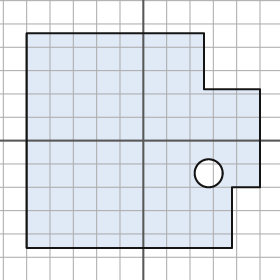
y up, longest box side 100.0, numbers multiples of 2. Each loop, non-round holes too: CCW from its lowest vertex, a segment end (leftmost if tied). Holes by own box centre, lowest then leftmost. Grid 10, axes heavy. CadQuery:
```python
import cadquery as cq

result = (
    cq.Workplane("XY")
    .moveTo(-50.0, -46.0)
    .lineTo(38.0, -46.0)
    .lineTo(38.0, -20.0)
    .lineTo(50.0, -20.0)
    .lineTo(50.0, 22.0)
    .lineTo(26.0, 22.0)
    .lineTo(26.0, 46.0)
    .lineTo(-50.0, 46.0)
    .close()
    .moveTo(28.0, -14.0)
    .circle(6.0)
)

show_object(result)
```